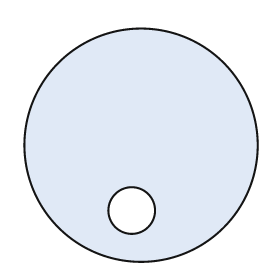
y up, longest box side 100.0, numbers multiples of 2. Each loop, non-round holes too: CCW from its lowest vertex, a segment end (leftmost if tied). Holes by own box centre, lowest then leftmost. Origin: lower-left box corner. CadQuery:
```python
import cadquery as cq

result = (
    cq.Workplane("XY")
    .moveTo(50.0, 50.0)
    .circle(50.0)
    .moveTo(46.0, 22.0)
    .circle(10.0)
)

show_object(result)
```